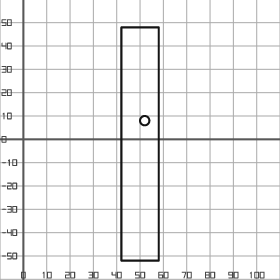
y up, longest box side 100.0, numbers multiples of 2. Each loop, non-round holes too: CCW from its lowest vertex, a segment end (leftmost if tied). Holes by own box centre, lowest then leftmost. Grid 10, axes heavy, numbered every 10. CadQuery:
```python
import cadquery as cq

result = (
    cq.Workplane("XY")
    .moveTo(42.0, -52.0)
    .lineTo(58.0, -52.0)
    .lineTo(58.0, 48.0)
    .lineTo(42.0, 48.0)
    .close()
    .moveTo(52.0, 8.0)
    .circle(2.0)
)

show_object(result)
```